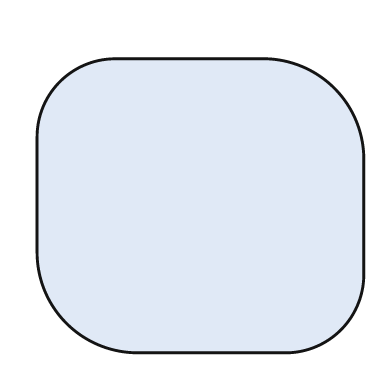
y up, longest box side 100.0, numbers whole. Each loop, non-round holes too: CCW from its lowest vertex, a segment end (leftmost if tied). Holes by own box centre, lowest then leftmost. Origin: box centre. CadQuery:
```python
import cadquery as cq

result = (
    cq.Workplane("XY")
    .moveTo(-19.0, -45.0)
    .lineTo(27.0, -45.0)
    .threePointArc((43.0, -38.0), (50.0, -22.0))
    .lineTo(50.0, 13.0)
    .threePointArc((41.0, 36.0), (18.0, 45.0))
    .lineTo(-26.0, 45.0)
    .threePointArc((-43.0, 38.0), (-50.0, 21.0))
    .lineTo(-50.0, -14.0)
    .threePointArc((-41.0, -36.0), (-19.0, -45.0))
    .close()
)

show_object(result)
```